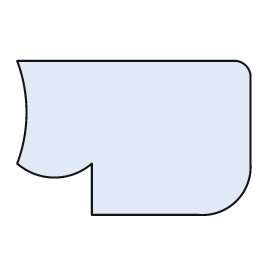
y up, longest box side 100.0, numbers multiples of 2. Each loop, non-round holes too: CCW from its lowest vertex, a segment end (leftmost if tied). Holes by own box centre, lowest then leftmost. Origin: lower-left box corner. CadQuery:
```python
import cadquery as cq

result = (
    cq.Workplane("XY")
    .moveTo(32.0, 0.0)
    .lineTo(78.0, 0.0)
    .threePointArc((94.0, 6.0), (100.0, 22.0))
    .lineTo(100.0, 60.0)
    .threePointArc((98.0, 64.0), (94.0, 66.0))
    .lineTo(0.0, 66.0)
    .threePointArc((4.0, 44.0), (0.0, 22.0))
    .threePointArc((16.0, 16.0), (32.0, 22.0))
    .close()
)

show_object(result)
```